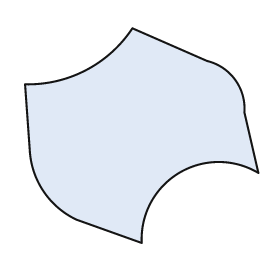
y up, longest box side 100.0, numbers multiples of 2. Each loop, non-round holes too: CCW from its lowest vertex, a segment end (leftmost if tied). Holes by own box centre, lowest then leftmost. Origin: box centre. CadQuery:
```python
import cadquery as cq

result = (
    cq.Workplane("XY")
    .moveTo(0.0, -46.0)
    .threePointArc((16.0, -16.0), (50.0, -16.0))
    .lineTo(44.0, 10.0)
    .threePointArc((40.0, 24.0), (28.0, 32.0))
    .lineTo(-4.0, 46.0)
    .threePointArc((-24.0, 28.0), (-50.0, 22.0))
    .lineTo(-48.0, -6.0)
    .threePointArc((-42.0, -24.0), (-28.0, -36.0))
    .close()
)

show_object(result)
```